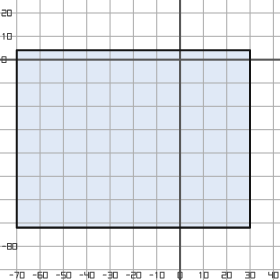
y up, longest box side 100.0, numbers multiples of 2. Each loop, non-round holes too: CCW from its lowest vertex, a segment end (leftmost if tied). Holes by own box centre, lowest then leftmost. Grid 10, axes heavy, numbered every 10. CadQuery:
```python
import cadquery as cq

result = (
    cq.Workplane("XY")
    .moveTo(-70.0, -72.0)
    .lineTo(30.0, -72.0)
    .lineTo(30.0, 4.0)
    .lineTo(-70.0, 4.0)
    .close()
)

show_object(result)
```